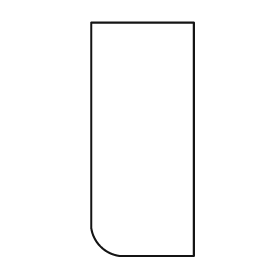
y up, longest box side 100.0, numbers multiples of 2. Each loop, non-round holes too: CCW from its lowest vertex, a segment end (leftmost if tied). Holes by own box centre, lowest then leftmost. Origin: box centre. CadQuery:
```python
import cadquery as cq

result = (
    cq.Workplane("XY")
    .moveTo(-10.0, -50.0)
    .lineTo(22.0, -50.0)
    .lineTo(22.0, 50.0)
    .lineTo(-22.0, 50.0)
    .lineTo(-22.0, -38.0)
    .threePointArc((-18.0, -46.0), (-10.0, -50.0))
    .close()
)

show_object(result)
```